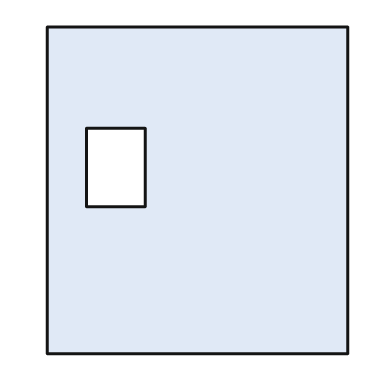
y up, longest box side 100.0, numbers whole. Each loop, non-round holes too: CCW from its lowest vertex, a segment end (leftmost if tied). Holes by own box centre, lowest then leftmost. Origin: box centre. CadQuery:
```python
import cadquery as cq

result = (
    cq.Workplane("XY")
    .moveTo(-46.0, -50.0)
    .lineTo(46.0, -50.0)
    .lineTo(46.0, 50.0)
    .lineTo(-46.0, 50.0)
    .close()
    .moveTo(-34.0, -5.0)
    .lineTo(-16.0, -5.0)
    .lineTo(-16.0, 19.0)
    .lineTo(-34.0, 19.0)
    .close()
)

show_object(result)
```